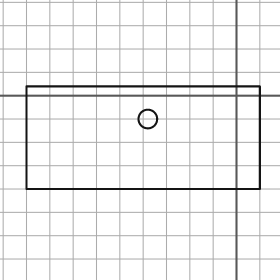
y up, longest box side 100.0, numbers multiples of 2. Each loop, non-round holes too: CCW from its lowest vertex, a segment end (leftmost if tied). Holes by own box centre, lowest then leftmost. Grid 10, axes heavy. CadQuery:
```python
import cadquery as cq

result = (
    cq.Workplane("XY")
    .moveTo(-90.0, -40.0)
    .lineTo(10.0, -40.0)
    .lineTo(10.0, 4.0)
    .lineTo(-90.0, 4.0)
    .close()
    .moveTo(-38.0, -10.0)
    .circle(4.0)
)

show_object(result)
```